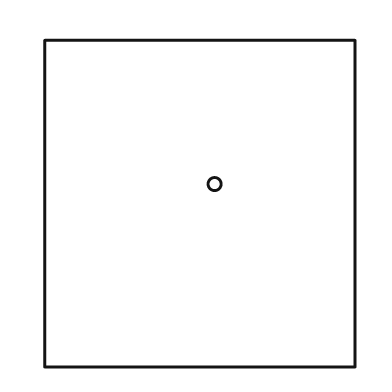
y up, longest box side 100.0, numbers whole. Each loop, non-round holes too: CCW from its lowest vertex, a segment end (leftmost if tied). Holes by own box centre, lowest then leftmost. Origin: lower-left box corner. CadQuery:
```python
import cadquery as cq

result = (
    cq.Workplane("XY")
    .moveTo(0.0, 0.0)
    .lineTo(95.0, 0.0)
    .lineTo(95.0, 100.0)
    .lineTo(0.0, 100.0)
    .close()
    .moveTo(52.0, 56.0)
    .circle(2.0)
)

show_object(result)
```